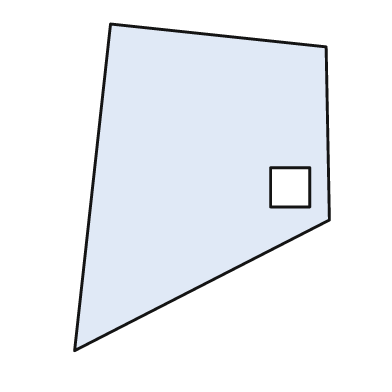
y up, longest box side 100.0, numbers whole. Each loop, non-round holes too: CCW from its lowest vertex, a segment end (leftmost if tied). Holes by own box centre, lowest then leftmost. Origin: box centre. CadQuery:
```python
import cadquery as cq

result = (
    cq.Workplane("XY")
    .moveTo(-39.0, -50.0)
    .lineTo(39.0, -10.0)
    .lineTo(38.0, 43.0)
    .lineTo(-28.0, 50.0)
    .close()
    .moveTo(21.0, -6.0)
    .lineTo(33.0, -6.0)
    .lineTo(33.0, 6.0)
    .lineTo(21.0, 6.0)
    .close()
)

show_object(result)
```